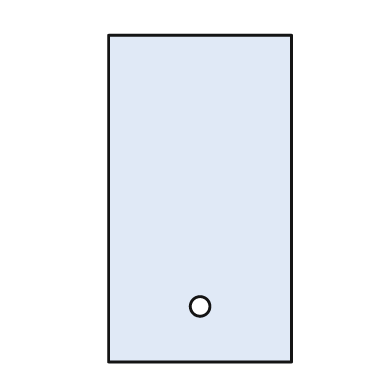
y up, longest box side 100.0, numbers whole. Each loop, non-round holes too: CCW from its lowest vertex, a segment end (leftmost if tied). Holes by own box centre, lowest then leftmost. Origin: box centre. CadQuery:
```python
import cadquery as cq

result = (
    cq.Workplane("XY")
    .moveTo(-28.0, -50.0)
    .lineTo(28.0, -50.0)
    .lineTo(28.0, 50.0)
    .lineTo(-28.0, 50.0)
    .close()
    .moveTo(0.0, -33.0)
    .circle(3.0)
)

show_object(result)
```